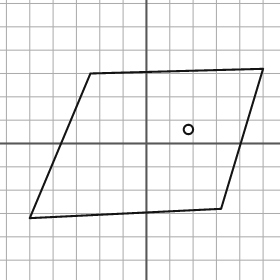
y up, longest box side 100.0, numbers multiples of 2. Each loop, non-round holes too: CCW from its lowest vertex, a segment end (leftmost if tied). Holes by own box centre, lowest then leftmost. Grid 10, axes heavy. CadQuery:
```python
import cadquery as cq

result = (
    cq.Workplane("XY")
    .moveTo(-50.0, -32.0)
    .lineTo(32.0, -28.0)
    .lineTo(50.0, 32.0)
    .lineTo(-24.0, 30.0)
    .close()
    .moveTo(18.0, 6.0)
    .circle(2.0)
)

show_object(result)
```